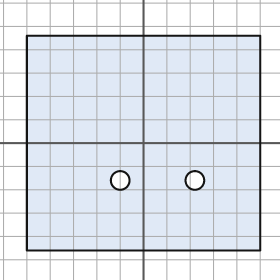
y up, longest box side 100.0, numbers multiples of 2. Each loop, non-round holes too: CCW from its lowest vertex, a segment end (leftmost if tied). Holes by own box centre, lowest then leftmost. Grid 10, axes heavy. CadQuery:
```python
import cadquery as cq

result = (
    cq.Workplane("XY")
    .moveTo(-50.0, -46.0)
    .lineTo(50.0, -46.0)
    .lineTo(50.0, 46.0)
    .lineTo(-50.0, 46.0)
    .close()
    .moveTo(-10.0, -16.0)
    .circle(4.0)
    .moveTo(22.0, -16.0)
    .circle(4.0)
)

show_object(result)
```